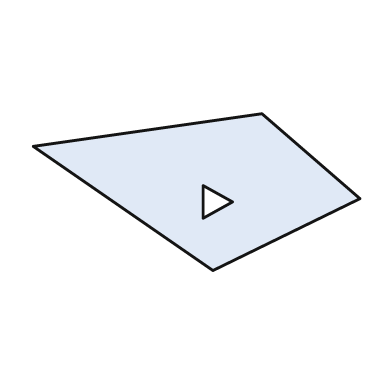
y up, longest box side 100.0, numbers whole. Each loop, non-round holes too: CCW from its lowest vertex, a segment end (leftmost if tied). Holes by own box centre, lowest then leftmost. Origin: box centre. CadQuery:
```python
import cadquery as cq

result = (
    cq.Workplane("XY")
    .moveTo(5.0, -24.0)
    .lineTo(50.0, -2.0)
    .lineTo(20.0, 24.0)
    .lineTo(-50.0, 14.0)
    .close()
    .moveTo(2.0, -8.0)
    .lineTo(11.0, -3.0)
    .lineTo(2.0, 2.0)
    .close()
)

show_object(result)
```